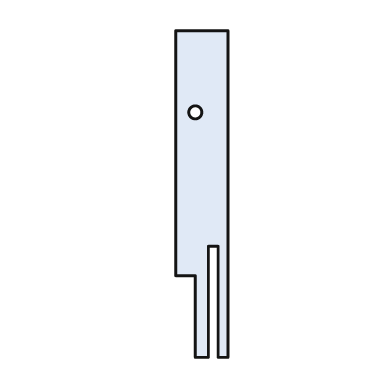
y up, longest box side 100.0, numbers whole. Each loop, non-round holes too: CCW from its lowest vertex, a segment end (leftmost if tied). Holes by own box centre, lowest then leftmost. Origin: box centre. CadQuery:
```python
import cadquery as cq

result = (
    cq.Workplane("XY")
    .moveTo(-2.0, -50.0)
    .lineTo(2.0, -50.0)
    .lineTo(2.0, -16.0)
    .lineTo(5.0, -16.0)
    .lineTo(5.0, -50.0)
    .lineTo(8.0, -50.0)
    .lineTo(8.0, 50.0)
    .lineTo(-8.0, 50.0)
    .lineTo(-8.0, -25.0)
    .lineTo(-2.0, -25.0)
    .close()
    .moveTo(-2.0, 25.0)
    .circle(2.0)
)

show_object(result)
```